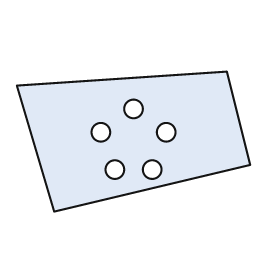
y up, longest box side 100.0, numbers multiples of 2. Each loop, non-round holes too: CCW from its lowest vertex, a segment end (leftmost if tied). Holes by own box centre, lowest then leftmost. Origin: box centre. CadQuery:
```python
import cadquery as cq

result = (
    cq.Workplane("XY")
    .moveTo(-34.0, -30.0)
    .lineTo(50.0, -10.0)
    .lineTo(40.0, 30.0)
    .lineTo(-50.0, 24.0)
    .close()
    .moveTo(-8.0, -12.0)
    .circle(4.0)
    .moveTo(8.0, -12.0)
    .circle(4.0)
    .moveTo(-14.0, 4.0)
    .circle(4.0)
    .moveTo(14.0, 4.0)
    .circle(4.0)
    .moveTo(0.0, 14.0)
    .circle(4.0)
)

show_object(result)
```